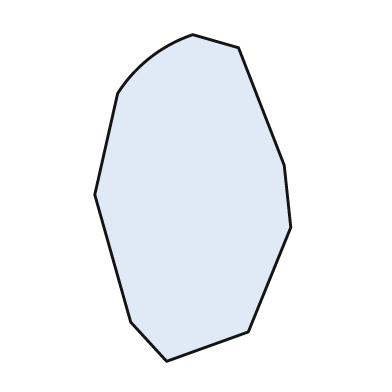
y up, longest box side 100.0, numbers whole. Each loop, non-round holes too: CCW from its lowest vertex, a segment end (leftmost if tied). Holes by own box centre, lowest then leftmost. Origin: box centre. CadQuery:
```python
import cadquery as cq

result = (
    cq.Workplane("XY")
    .moveTo(-8.0, -50.0)
    .lineTo(17.0, -41.0)
    .lineTo(30.0, -9.0)
    .lineTo(28.0, 10.0)
    .lineTo(14.0, 46.0)
    .lineTo(0.0, 50.0)
    .threePointArc((-13.0, 43.0), (-23.0, 32.0))
    .lineTo(-30.0, 1.0)
    .lineTo(-19.0, -38.0)
    .close()
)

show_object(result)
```